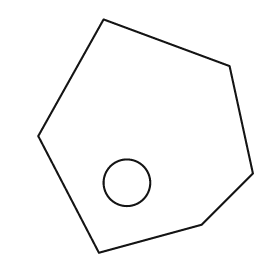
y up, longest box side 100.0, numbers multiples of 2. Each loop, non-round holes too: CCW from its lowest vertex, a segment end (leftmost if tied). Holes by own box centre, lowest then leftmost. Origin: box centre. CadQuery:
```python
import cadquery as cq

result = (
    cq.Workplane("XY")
    .moveTo(-20.0, -50.0)
    .lineTo(24.0, -38.0)
    .lineTo(46.0, -16.0)
    .lineTo(36.0, 30.0)
    .lineTo(-18.0, 50.0)
    .lineTo(-46.0, 0.0)
    .close()
    .moveTo(-8.0, -20.0)
    .circle(10.0)
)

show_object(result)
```